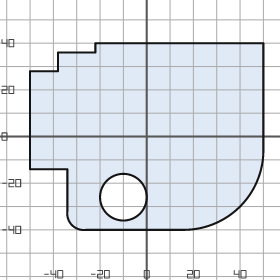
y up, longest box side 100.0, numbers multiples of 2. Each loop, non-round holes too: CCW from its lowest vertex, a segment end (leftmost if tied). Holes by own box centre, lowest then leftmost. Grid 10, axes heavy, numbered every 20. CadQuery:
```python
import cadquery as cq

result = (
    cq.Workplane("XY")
    .moveTo(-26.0, -40.0)
    .lineTo(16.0, -40.0)
    .threePointArc((40.0, -30.0), (50.0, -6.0))
    .lineTo(50.0, 40.0)
    .lineTo(-22.0, 40.0)
    .lineTo(-22.0, 36.0)
    .lineTo(-38.0, 36.0)
    .lineTo(-38.0, 28.0)
    .lineTo(-50.0, 28.0)
    .lineTo(-50.0, -14.0)
    .lineTo(-34.0, -14.0)
    .lineTo(-34.0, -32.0)
    .threePointArc((-32.0, -38.0), (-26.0, -40.0))
    .close()
    .moveTo(-10.0, -26.0)
    .circle(10.0)
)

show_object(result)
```